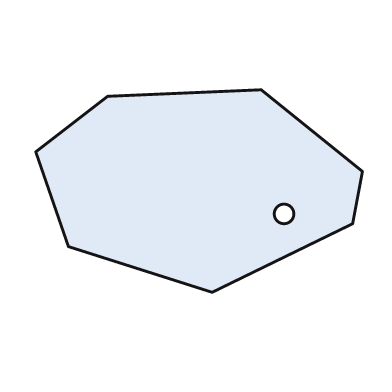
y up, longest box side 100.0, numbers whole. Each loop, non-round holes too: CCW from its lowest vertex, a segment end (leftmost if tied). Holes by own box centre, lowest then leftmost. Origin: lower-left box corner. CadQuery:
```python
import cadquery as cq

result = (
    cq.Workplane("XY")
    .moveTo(54.0, 0.0)
    .lineTo(97.0, 21.0)
    .lineTo(100.0, 37.0)
    .lineTo(69.0, 62.0)
    .lineTo(22.0, 60.0)
    .lineTo(0.0, 43.0)
    .lineTo(10.0, 14.0)
    .close()
    .moveTo(76.0, 24.0)
    .circle(3.0)
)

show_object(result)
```